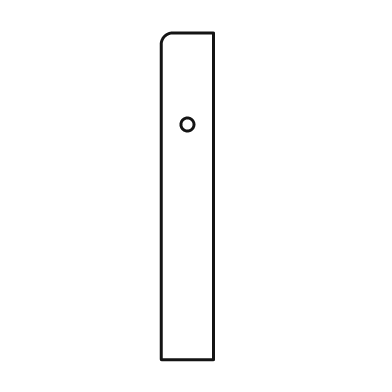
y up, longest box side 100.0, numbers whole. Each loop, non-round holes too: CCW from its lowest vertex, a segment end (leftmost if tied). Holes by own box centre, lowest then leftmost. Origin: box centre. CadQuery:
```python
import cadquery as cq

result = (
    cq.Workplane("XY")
    .moveTo(-8.0, -50.0)
    .lineTo(8.0, -50.0)
    .lineTo(8.0, 50.0)
    .lineTo(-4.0, 50.0)
    .threePointArc((-7.0, 49.0), (-8.0, 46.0))
    .close()
    .moveTo(0.0, 22.0)
    .circle(2.0)
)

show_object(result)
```